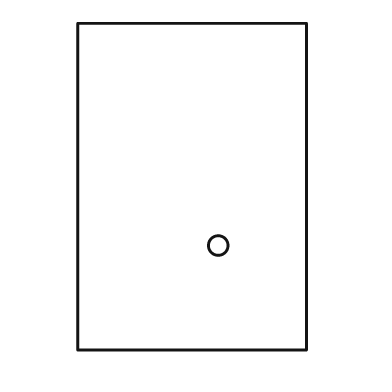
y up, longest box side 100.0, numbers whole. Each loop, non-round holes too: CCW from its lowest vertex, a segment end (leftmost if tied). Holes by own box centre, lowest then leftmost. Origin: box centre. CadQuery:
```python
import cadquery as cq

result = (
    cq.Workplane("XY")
    .moveTo(-35.0, -50.0)
    .lineTo(35.0, -50.0)
    .lineTo(35.0, 50.0)
    .lineTo(-35.0, 50.0)
    .close()
    .moveTo(8.0, -18.0)
    .circle(3.0)
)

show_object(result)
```